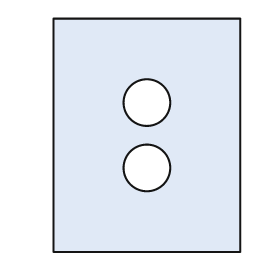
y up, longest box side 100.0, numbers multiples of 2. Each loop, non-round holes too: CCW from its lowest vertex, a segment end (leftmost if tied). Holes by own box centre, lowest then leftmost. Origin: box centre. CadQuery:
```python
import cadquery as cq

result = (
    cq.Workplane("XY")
    .moveTo(-40.0, -50.0)
    .lineTo(40.0, -50.0)
    .lineTo(40.0, 50.0)
    .lineTo(-40.0, 50.0)
    .close()
    .moveTo(0.0, -14.0)
    .circle(10.0)
    .moveTo(0.0, 14.0)
    .circle(10.0)
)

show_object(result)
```